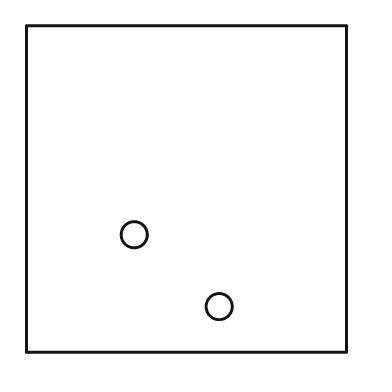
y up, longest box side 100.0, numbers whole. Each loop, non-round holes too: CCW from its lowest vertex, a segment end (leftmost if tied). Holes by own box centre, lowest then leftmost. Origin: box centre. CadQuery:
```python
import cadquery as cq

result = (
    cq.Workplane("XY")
    .moveTo(-49.0, -50.0)
    .lineTo(49.0, -50.0)
    .lineTo(49.0, 50.0)
    .lineTo(-49.0, 50.0)
    .close()
    .moveTo(10.0, -36.0)
    .circle(4.0)
    .moveTo(-16.0, -14.0)
    .circle(4.0)
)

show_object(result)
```